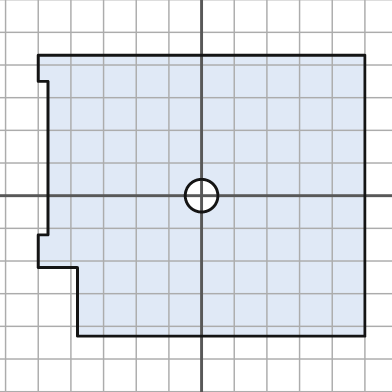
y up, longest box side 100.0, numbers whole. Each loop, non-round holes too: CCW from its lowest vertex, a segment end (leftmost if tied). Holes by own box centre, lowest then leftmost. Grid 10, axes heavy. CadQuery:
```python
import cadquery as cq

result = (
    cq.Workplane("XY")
    .moveTo(-38.0, -43.0)
    .lineTo(50.0, -43.0)
    .lineTo(50.0, 43.0)
    .lineTo(-50.0, 43.0)
    .lineTo(-50.0, 35.0)
    .lineTo(-47.0, 35.0)
    .lineTo(-47.0, -12.0)
    .lineTo(-50.0, -12.0)
    .lineTo(-50.0, -22.0)
    .lineTo(-38.0, -22.0)
    .close()
    .moveTo(0.0, 0.0)
    .circle(5.0)
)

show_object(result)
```